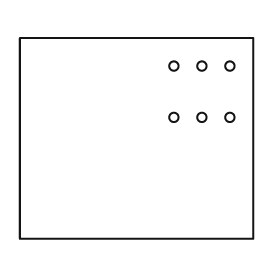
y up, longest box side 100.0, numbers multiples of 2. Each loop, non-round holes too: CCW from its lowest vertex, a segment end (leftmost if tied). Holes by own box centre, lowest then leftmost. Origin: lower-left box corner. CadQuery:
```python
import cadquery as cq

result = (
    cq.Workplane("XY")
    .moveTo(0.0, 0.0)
    .lineTo(100.0, 0.0)
    .lineTo(100.0, 86.0)
    .lineTo(0.0, 86.0)
    .close()
    .moveTo(66.0, 52.0)
    .circle(2.0)
    .moveTo(78.0, 52.0)
    .circle(2.0)
    .moveTo(90.0, 52.0)
    .circle(2.0)
    .moveTo(66.0, 74.0)
    .circle(2.0)
    .moveTo(78.0, 74.0)
    .circle(2.0)
    .moveTo(90.0, 74.0)
    .circle(2.0)
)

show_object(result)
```